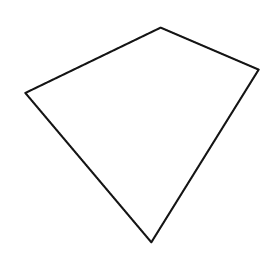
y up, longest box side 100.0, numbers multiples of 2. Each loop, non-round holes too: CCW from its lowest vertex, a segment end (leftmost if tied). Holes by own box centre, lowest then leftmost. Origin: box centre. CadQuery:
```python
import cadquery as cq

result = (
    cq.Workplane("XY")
    .moveTo(4.0, -46.0)
    .lineTo(50.0, 28.0)
    .lineTo(8.0, 46.0)
    .lineTo(-50.0, 18.0)
    .close()
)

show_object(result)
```